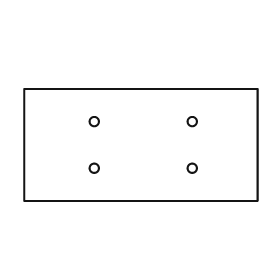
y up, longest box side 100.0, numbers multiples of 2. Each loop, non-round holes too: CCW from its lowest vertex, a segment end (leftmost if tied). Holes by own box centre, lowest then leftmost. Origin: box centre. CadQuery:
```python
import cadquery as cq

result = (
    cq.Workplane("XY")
    .moveTo(-50.0, -24.0)
    .lineTo(50.0, -24.0)
    .lineTo(50.0, 24.0)
    .lineTo(-50.0, 24.0)
    .close()
    .moveTo(-20.0, -10.0)
    .circle(2.0)
    .moveTo(22.0, -10.0)
    .circle(2.0)
    .moveTo(-20.0, 10.0)
    .circle(2.0)
    .moveTo(22.0, 10.0)
    .circle(2.0)
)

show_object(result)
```